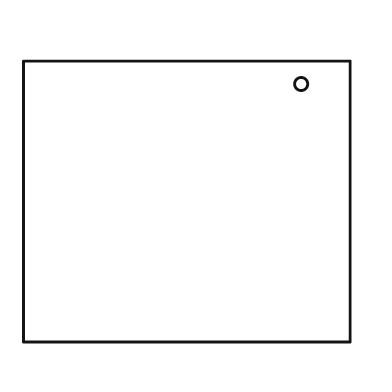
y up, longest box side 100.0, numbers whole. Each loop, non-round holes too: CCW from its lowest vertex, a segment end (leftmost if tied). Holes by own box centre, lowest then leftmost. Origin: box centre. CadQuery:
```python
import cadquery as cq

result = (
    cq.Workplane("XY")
    .moveTo(-50.0, -43.0)
    .lineTo(50.0, -43.0)
    .lineTo(50.0, 43.0)
    .lineTo(-50.0, 43.0)
    .close()
    .moveTo(35.0, 36.0)
    .circle(2.0)
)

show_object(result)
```